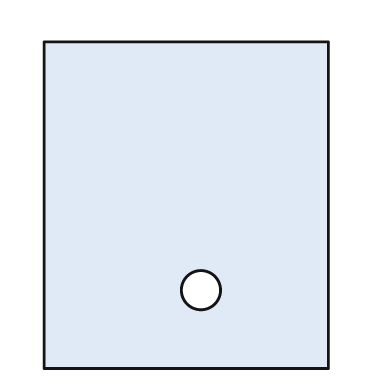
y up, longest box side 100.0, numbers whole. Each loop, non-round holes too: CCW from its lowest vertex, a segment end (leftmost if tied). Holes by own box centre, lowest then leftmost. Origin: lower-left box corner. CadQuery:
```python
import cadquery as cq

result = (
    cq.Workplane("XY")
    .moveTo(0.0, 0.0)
    .lineTo(87.0, 0.0)
    .lineTo(87.0, 100.0)
    .lineTo(0.0, 100.0)
    .close()
    .moveTo(48.0, 24.0)
    .circle(6.0)
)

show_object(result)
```